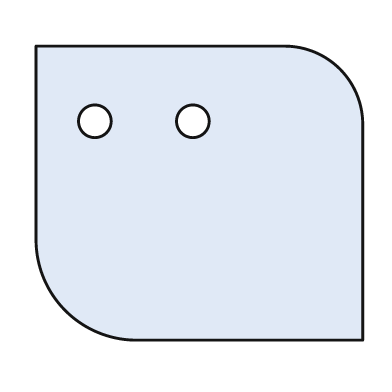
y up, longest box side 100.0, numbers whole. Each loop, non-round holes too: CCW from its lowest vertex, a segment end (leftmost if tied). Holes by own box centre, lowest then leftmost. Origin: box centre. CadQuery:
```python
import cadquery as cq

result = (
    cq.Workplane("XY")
    .moveTo(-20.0, -45.0)
    .lineTo(50.0, -45.0)
    .lineTo(50.0, 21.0)
    .threePointArc((43.0, 38.0), (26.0, 45.0))
    .lineTo(-50.0, 45.0)
    .lineTo(-50.0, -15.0)
    .threePointArc((-41.0, -36.0), (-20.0, -45.0))
    .close()
    .moveTo(-32.0, 22.0)
    .circle(5.0)
    .moveTo(-2.0, 22.0)
    .circle(5.0)
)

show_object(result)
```